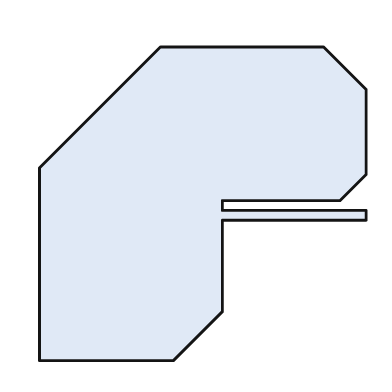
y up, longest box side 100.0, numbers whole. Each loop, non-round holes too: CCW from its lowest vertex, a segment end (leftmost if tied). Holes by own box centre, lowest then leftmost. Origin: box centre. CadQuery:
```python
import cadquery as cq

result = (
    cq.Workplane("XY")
    .moveTo(-50.0, -48.0)
    .lineTo(-9.0, -48.0)
    .lineTo(6.0, -33.0)
    .lineTo(6.0, -5.0)
    .lineTo(50.0, -5.0)
    .lineTo(50.0, -2.0)
    .lineTo(6.0, -2.0)
    .lineTo(6.0, 1.0)
    .lineTo(42.0, 1.0)
    .lineTo(50.0, 9.0)
    .lineTo(50.0, 35.0)
    .lineTo(37.0, 48.0)
    .lineTo(-13.0, 48.0)
    .lineTo(-50.0, 11.0)
    .close()
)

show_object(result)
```